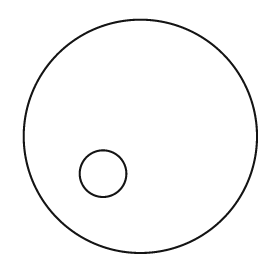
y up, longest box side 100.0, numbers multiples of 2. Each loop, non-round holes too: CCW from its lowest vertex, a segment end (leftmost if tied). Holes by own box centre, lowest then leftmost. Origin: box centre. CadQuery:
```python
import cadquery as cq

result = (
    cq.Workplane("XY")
    .moveTo(0.0, 0.0)
    .circle(50.0)
    .moveTo(-16.0, -16.0)
    .circle(10.0)
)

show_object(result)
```